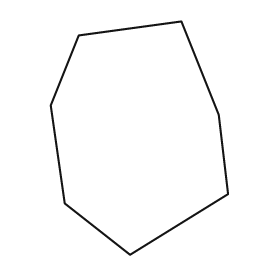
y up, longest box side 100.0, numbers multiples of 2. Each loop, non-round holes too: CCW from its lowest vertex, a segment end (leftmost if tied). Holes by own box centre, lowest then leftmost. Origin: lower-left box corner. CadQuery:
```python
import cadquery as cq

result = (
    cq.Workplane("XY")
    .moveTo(34.0, 0.0)
    .lineTo(76.0, 26.0)
    .lineTo(72.0, 60.0)
    .lineTo(56.0, 100.0)
    .lineTo(12.0, 94.0)
    .lineTo(0.0, 64.0)
    .lineTo(6.0, 22.0)
    .close()
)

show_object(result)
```